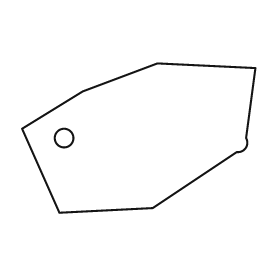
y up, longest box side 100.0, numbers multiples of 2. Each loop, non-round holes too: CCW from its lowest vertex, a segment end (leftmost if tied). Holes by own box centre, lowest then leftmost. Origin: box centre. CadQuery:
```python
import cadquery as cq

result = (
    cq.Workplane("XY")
    .moveTo(-34.0, -32.0)
    .lineTo(6.0, -30.0)
    .lineTo(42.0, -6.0)
    .threePointArc((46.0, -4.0), (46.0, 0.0))
    .lineTo(50.0, 30.0)
    .lineTo(8.0, 32.0)
    .lineTo(-24.0, 20.0)
    .lineTo(-50.0, 4.0)
    .close()
    .moveTo(-32.0, 0.0)
    .circle(4.0)
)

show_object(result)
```